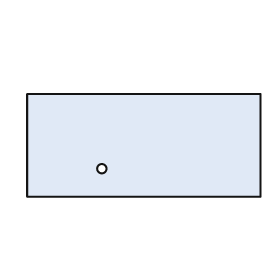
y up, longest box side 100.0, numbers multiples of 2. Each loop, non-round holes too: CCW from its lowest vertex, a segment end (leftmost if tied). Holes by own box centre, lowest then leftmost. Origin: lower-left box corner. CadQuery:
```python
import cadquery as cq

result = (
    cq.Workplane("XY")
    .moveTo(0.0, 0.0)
    .lineTo(100.0, 0.0)
    .lineTo(100.0, 44.0)
    .lineTo(0.0, 44.0)
    .close()
    .moveTo(32.0, 12.0)
    .circle(2.0)
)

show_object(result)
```